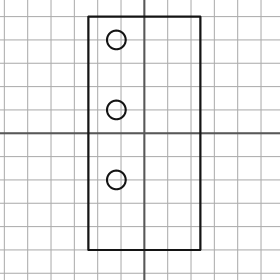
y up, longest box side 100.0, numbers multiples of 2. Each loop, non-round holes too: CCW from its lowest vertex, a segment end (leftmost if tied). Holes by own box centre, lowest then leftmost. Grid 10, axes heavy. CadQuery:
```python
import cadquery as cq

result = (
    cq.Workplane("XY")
    .moveTo(-24.0, -50.0)
    .lineTo(24.0, -50.0)
    .lineTo(24.0, 50.0)
    .lineTo(-24.0, 50.0)
    .close()
    .moveTo(-12.0, -20.0)
    .circle(4.0)
    .moveTo(-12.0, 10.0)
    .circle(4.0)
    .moveTo(-12.0, 40.0)
    .circle(4.0)
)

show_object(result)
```